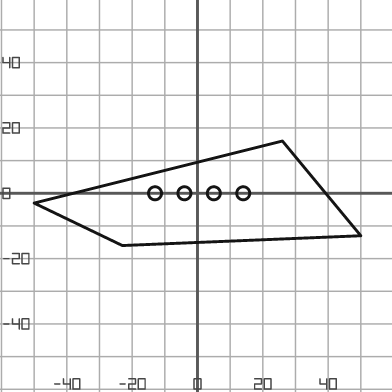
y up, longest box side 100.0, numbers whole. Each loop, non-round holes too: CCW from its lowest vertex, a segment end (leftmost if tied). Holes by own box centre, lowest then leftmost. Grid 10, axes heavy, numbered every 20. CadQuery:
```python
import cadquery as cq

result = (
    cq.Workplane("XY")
    .moveTo(-23.0, -16.0)
    .lineTo(50.0, -13.0)
    .lineTo(26.0, 16.0)
    .lineTo(-50.0, -3.0)
    .close()
    .moveTo(-13.0, 0.0)
    .circle(2.0)
    .moveTo(-4.0, 0.0)
    .circle(2.0)
    .moveTo(5.0, 0.0)
    .circle(2.0)
    .moveTo(14.0, 0.0)
    .circle(2.0)
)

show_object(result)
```